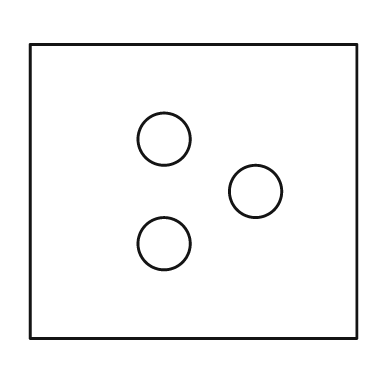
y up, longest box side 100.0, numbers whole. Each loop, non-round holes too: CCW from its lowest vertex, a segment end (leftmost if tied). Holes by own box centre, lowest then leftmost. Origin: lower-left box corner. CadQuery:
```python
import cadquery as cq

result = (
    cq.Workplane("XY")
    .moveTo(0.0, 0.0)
    .lineTo(100.0, 0.0)
    .lineTo(100.0, 90.0)
    .lineTo(0.0, 90.0)
    .close()
    .moveTo(41.0, 29.0)
    .circle(8.0)
    .moveTo(69.0, 45.0)
    .circle(8.0)
    .moveTo(41.0, 61.0)
    .circle(8.0)
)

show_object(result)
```